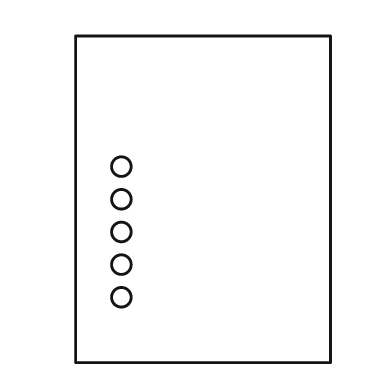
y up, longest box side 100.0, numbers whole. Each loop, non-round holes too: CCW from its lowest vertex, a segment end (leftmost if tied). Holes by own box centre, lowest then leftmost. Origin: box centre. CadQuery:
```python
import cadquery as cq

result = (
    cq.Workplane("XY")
    .moveTo(-39.0, -50.0)
    .lineTo(39.0, -50.0)
    .lineTo(39.0, 50.0)
    .lineTo(-39.0, 50.0)
    .close()
    .moveTo(-25.0, -30.0)
    .circle(3.0)
    .moveTo(-25.0, -20.0)
    .circle(3.0)
    .moveTo(-25.0, -10.0)
    .circle(3.0)
    .moveTo(-25.0, 0.0)
    .circle(3.0)
    .moveTo(-25.0, 10.0)
    .circle(3.0)
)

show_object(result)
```